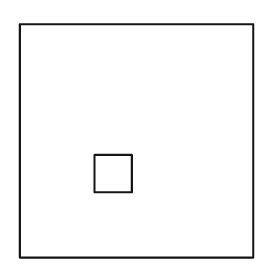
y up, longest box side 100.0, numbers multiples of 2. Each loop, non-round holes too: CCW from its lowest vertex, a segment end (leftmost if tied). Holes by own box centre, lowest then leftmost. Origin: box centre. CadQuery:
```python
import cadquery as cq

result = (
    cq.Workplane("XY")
    .moveTo(-50.0, -50.0)
    .lineTo(50.0, -50.0)
    .lineTo(50.0, 50.0)
    .lineTo(-50.0, 50.0)
    .close()
    .moveTo(-18.0, -22.0)
    .lineTo(-2.0, -22.0)
    .lineTo(-2.0, -6.0)
    .lineTo(-18.0, -6.0)
    .close()
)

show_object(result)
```